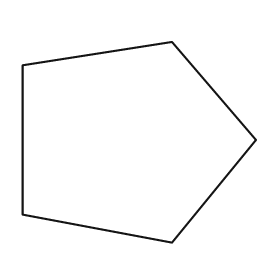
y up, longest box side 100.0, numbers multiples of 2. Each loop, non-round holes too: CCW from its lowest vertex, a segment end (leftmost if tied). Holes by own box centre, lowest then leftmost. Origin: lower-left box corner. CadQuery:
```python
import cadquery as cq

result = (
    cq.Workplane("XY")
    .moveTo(64.0, 0.0)
    .lineTo(100.0, 44.0)
    .lineTo(64.0, 86.0)
    .lineTo(0.0, 76.0)
    .lineTo(0.0, 12.0)
    .close()
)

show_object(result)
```